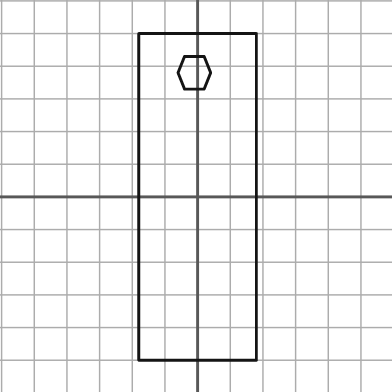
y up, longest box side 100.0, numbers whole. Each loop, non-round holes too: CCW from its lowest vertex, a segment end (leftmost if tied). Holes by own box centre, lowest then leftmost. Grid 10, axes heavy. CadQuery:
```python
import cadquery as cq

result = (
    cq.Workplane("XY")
    .moveTo(-18.0, -50.0)
    .lineTo(18.0, -50.0)
    .lineTo(18.0, 50.0)
    .lineTo(-18.0, 50.0)
    .close()
    .moveTo(-4.0, 33.0)
    .lineTo(2.0, 33.0)
    .lineTo(4.0, 38.0)
    .lineTo(2.0, 43.0)
    .lineTo(-4.0, 43.0)
    .lineTo(-6.0, 38.0)
    .close()
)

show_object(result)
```